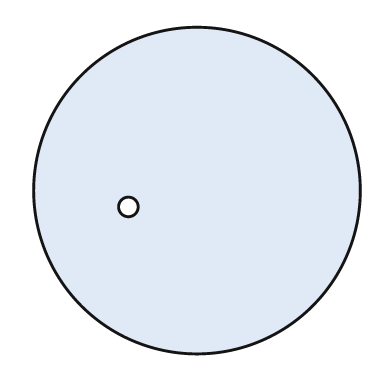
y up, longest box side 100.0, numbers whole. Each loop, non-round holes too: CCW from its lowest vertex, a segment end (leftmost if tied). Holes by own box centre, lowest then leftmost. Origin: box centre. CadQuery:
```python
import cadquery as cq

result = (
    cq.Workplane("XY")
    .moveTo(0.0, 0.0)
    .circle(50.0)
    .moveTo(-21.0, -5.0)
    .circle(3.0)
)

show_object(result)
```